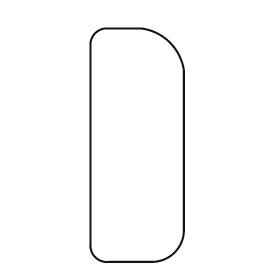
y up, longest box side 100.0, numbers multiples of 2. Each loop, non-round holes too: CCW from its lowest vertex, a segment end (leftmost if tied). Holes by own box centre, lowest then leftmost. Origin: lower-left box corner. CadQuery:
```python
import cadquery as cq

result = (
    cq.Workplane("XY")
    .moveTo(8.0, 0.0)
    .lineTo(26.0, 0.0)
    .threePointArc((36.0, 4.0), (40.0, 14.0))
    .lineTo(40.0, 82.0)
    .threePointArc((34.0, 94.0), (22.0, 100.0))
    .lineTo(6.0, 100.0)
    .threePointArc((2.0, 98.0), (0.0, 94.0))
    .lineTo(0.0, 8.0)
    .threePointArc((2.0, 2.0), (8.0, 0.0))
    .close()
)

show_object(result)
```